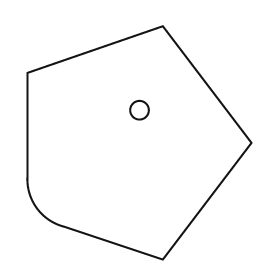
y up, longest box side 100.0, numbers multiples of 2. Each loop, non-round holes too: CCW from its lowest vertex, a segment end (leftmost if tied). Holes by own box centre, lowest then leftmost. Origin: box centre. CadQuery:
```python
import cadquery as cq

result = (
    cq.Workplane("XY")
    .moveTo(10.0, -50.0)
    .lineTo(48.0, 0.0)
    .lineTo(10.0, 50.0)
    .lineTo(-48.0, 30.0)
    .lineTo(-48.0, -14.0)
    .threePointArc((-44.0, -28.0), (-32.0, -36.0))
    .close()
    .moveTo(0.0, 14.0)
    .circle(4.0)
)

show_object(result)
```